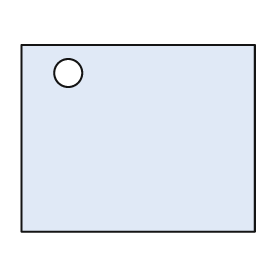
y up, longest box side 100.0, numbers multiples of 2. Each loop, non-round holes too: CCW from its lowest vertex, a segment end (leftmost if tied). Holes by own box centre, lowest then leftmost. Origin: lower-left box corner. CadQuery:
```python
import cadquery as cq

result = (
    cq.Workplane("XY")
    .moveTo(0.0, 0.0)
    .lineTo(100.0, 0.0)
    .lineTo(100.0, 80.0)
    .lineTo(0.0, 80.0)
    .close()
    .moveTo(20.0, 68.0)
    .circle(6.0)
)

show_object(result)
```